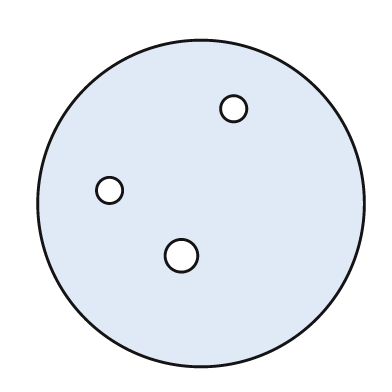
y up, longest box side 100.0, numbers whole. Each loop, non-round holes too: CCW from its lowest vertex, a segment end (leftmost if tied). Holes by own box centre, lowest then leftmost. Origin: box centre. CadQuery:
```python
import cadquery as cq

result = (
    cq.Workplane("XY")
    .moveTo(0.0, 0.0)
    .circle(50.0)
    .moveTo(-6.0, -16.0)
    .circle(5.0)
    .moveTo(-28.0, 4.0)
    .circle(4.0)
    .moveTo(10.0, 29.0)
    .circle(4.0)
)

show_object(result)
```